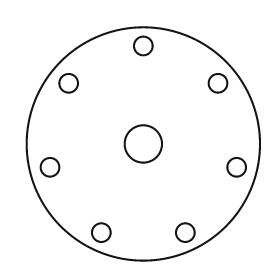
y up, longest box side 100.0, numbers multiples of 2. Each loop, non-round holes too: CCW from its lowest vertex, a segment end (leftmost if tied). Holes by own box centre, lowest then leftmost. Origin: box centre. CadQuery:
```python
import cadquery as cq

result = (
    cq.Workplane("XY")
    .moveTo(0.0, 0.0)
    .circle(50.0)
    .moveTo(-18.0, -38.0)
    .circle(4.0)
    .moveTo(18.0, -38.0)
    .circle(4.0)
    .moveTo(-40.0, -10.0)
    .circle(4.0)
    .moveTo(40.0, -10.0)
    .circle(4.0)
    .moveTo(0.0, 0.0)
    .circle(8.0)
    .moveTo(-32.0, 26.0)
    .circle(4.0)
    .moveTo(32.0, 26.0)
    .circle(4.0)
    .moveTo(0.0, 42.0)
    .circle(4.0)
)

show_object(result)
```